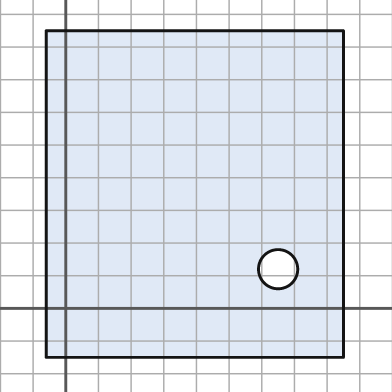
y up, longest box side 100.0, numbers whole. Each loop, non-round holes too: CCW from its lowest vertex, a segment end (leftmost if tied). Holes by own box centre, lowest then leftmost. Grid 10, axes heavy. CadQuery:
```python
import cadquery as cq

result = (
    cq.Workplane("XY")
    .moveTo(-6.0, -15.0)
    .lineTo(85.0, -15.0)
    .lineTo(85.0, 85.0)
    .lineTo(-6.0, 85.0)
    .close()
    .moveTo(65.0, 12.0)
    .circle(6.0)
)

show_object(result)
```